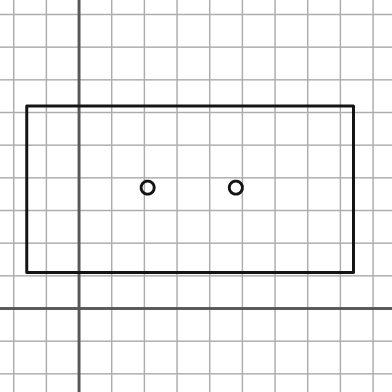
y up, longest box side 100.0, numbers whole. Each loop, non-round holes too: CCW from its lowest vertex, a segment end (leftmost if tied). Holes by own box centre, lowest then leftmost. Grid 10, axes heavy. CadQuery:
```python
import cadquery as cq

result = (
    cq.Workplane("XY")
    .moveTo(-16.0, 11.0)
    .lineTo(84.0, 11.0)
    .lineTo(84.0, 62.0)
    .lineTo(-16.0, 62.0)
    .close()
    .moveTo(21.0, 37.0)
    .circle(2.0)
    .moveTo(48.0, 37.0)
    .circle(2.0)
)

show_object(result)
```